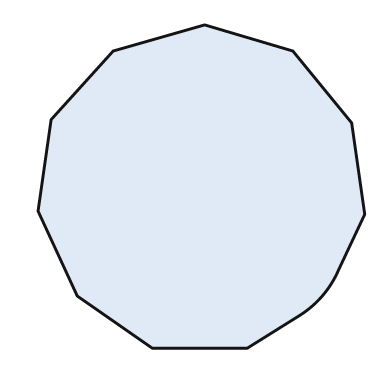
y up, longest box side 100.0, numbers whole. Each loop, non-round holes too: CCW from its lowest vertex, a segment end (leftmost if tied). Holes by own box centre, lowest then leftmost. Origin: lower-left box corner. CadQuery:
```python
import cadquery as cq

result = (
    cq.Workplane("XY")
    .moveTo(35.0, 0.0)
    .lineTo(64.0, 0.0)
    .lineTo(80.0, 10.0)
    .threePointArc((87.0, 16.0), (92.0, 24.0))
    .lineTo(100.0, 41.0)
    .lineTo(96.0, 69.0)
    .lineTo(78.0, 91.0)
    .lineTo(51.0, 99.0)
    .lineTo(23.0, 91.0)
    .lineTo(4.0, 70.0)
    .lineTo(0.0, 42.0)
    .lineTo(12.0, 16.0)
    .close()
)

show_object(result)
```